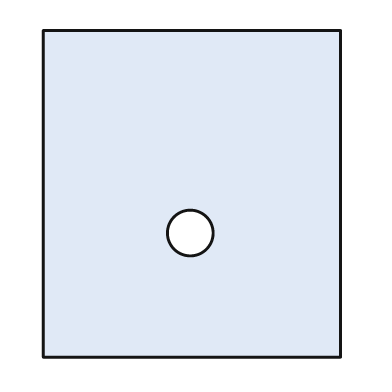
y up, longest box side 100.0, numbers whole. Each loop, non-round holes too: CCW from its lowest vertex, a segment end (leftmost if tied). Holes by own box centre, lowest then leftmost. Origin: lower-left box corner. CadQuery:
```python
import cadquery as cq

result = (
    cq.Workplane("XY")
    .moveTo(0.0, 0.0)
    .lineTo(91.0, 0.0)
    .lineTo(91.0, 100.0)
    .lineTo(0.0, 100.0)
    .close()
    .moveTo(45.0, 38.0)
    .circle(7.0)
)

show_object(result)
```